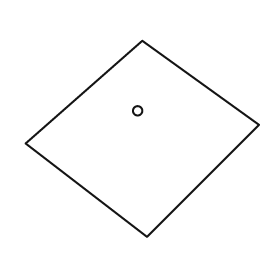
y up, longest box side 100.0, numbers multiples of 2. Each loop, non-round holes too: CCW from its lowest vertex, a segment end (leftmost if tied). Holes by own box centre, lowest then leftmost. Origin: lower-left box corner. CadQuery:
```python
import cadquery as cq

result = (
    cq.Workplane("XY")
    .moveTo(52.0, 0.0)
    .lineTo(100.0, 48.0)
    .lineTo(50.0, 84.0)
    .lineTo(0.0, 40.0)
    .close()
    .moveTo(48.0, 54.0)
    .circle(2.0)
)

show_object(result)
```